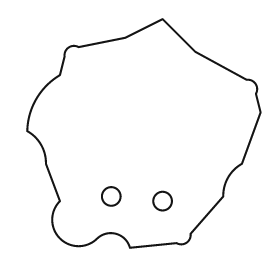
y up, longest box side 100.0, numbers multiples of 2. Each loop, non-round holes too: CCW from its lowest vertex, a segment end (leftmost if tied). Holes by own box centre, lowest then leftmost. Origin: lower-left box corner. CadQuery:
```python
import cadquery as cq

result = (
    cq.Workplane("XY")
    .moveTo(44.0, 0.0)
    .lineTo(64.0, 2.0)
    .threePointArc((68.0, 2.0), (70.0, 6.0))
    .lineTo(84.0, 22.0)
    .threePointArc((86.0, 30.0), (92.0, 36.0))
    .lineTo(100.0, 58.0)
    .lineTo(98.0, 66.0)
    .threePointArc((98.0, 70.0), (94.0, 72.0))
    .lineTo(72.0, 84.0)
    .lineTo(58.0, 98.0)
    .lineTo(42.0, 90.0)
    .lineTo(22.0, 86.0)
    .threePointArc((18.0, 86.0), (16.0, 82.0))
    .lineTo(14.0, 74.0)
    .threePointArc((4.0, 64.0), (0.0, 50.0))
    .threePointArc((6.0, 44.0), (8.0, 36.0))
    .lineTo(14.0, 20.0)
    .threePointArc((14.0, 4.0), (30.0, 4.0))
    .threePointArc((38.0, 6.0), (44.0, 0.0))
    .close()
    .moveTo(58.0, 20.0)
    .circle(4.0)
    .moveTo(36.0, 22.0)
    .circle(4.0)
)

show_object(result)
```